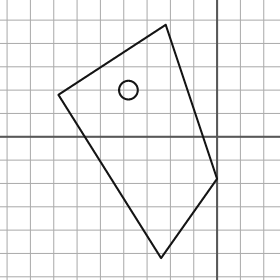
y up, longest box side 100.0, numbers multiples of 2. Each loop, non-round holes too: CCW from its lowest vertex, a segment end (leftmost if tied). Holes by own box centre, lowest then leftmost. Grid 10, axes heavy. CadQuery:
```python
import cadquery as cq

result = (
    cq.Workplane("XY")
    .moveTo(-24.0, -52.0)
    .lineTo(0.0, -18.0)
    .lineTo(-22.0, 48.0)
    .lineTo(-68.0, 18.0)
    .close()
    .moveTo(-38.0, 20.0)
    .circle(4.0)
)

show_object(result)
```